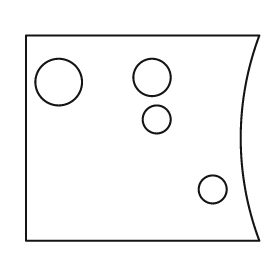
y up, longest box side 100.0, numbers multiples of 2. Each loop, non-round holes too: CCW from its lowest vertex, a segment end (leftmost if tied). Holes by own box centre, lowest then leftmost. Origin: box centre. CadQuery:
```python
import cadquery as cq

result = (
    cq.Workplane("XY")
    .moveTo(-50.0, -44.0)
    .lineTo(50.0, -44.0)
    .threePointArc((42.0, 0.0), (50.0, 44.0))
    .lineTo(-50.0, 44.0)
    .close()
    .moveTo(30.0, -22.0)
    .circle(6.0)
    .moveTo(6.0, 8.0)
    .circle(6.0)
    .moveTo(-36.0, 24.0)
    .circle(10.0)
    .moveTo(4.0, 26.0)
    .circle(8.0)
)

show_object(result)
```